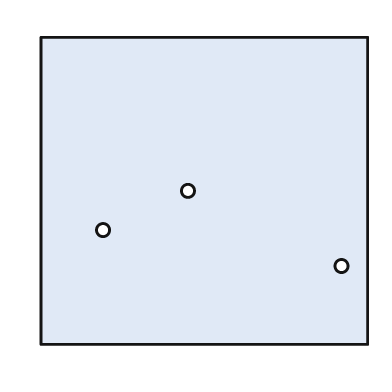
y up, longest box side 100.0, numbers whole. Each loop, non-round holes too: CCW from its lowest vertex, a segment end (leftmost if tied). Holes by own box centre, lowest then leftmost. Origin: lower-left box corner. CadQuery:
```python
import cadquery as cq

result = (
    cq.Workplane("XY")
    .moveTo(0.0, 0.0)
    .lineTo(100.0, 0.0)
    .lineTo(100.0, 94.0)
    .lineTo(0.0, 94.0)
    .close()
    .moveTo(92.0, 24.0)
    .circle(2.0)
    .moveTo(19.0, 35.0)
    .circle(2.0)
    .moveTo(45.0, 47.0)
    .circle(2.0)
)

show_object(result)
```